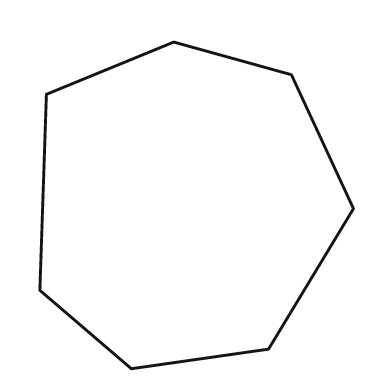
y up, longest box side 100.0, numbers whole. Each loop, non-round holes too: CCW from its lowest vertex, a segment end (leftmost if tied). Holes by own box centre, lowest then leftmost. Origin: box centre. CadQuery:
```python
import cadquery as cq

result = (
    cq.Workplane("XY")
    .moveTo(-20.0, -50.0)
    .lineTo(22.0, -44.0)
    .lineTo(48.0, -1.0)
    .lineTo(29.0, 40.0)
    .lineTo(-7.0, 50.0)
    .lineTo(-46.0, 34.0)
    .lineTo(-48.0, -26.0)
    .close()
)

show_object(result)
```